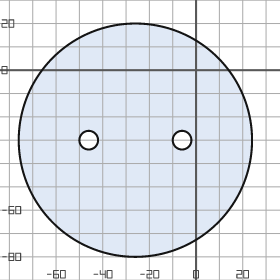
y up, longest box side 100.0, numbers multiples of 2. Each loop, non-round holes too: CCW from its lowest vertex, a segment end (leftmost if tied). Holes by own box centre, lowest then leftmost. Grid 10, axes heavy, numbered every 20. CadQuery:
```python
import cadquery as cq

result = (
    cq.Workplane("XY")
    .moveTo(-26.0, -30.0)
    .circle(50.0)
    .moveTo(-46.0, -30.0)
    .circle(4.0)
    .moveTo(-6.0, -30.0)
    .circle(4.0)
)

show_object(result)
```